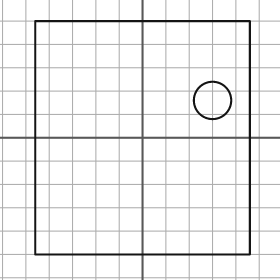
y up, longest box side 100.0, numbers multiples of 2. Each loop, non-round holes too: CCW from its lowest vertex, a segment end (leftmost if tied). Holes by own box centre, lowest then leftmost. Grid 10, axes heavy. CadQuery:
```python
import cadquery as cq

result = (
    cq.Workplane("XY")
    .moveTo(-46.0, -50.0)
    .lineTo(46.0, -50.0)
    .lineTo(46.0, 50.0)
    .lineTo(-46.0, 50.0)
    .close()
    .moveTo(30.0, 16.0)
    .circle(8.0)
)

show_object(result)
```